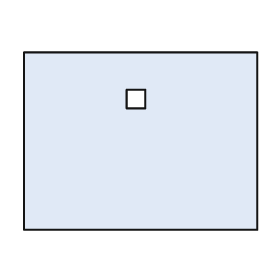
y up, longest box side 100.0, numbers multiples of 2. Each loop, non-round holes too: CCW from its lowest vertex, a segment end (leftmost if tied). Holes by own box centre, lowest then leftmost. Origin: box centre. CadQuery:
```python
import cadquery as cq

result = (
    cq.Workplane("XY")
    .moveTo(-50.0, -38.0)
    .lineTo(50.0, -38.0)
    .lineTo(50.0, 38.0)
    .lineTo(-50.0, 38.0)
    .close()
    .moveTo(-6.0, 14.0)
    .lineTo(2.0, 14.0)
    .lineTo(2.0, 22.0)
    .lineTo(-6.0, 22.0)
    .close()
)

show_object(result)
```